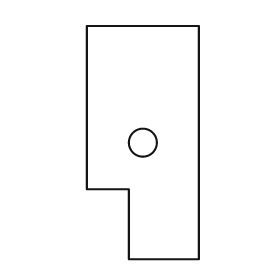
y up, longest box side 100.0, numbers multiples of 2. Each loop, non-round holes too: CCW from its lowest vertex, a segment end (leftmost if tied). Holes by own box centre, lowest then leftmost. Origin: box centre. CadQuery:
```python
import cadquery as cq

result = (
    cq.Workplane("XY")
    .moveTo(-6.0, -50.0)
    .lineTo(24.0, -50.0)
    .lineTo(24.0, 50.0)
    .lineTo(-24.0, 50.0)
    .lineTo(-24.0, -20.0)
    .lineTo(-6.0, -20.0)
    .close()
    .moveTo(0.0, 0.0)
    .circle(6.0)
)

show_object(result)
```